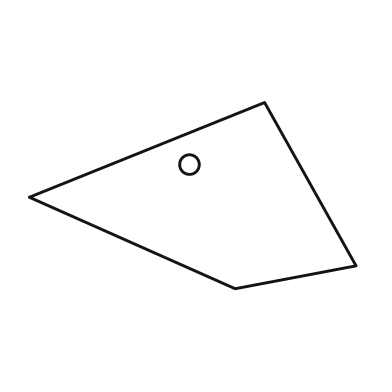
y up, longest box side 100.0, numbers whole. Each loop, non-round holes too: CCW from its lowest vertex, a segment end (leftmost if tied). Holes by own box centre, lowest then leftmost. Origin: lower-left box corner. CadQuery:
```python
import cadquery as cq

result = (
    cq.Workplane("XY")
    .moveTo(63.0, 0.0)
    .lineTo(100.0, 7.0)
    .lineTo(72.0, 57.0)
    .lineTo(0.0, 28.0)
    .close()
    .moveTo(49.0, 38.0)
    .circle(3.0)
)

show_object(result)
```